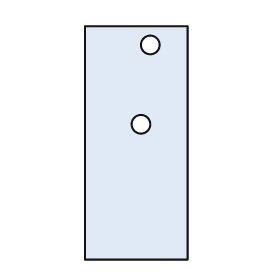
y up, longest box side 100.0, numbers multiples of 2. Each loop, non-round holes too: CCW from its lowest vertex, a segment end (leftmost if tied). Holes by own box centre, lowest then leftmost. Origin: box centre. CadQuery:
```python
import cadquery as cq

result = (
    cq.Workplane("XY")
    .moveTo(-22.0, -50.0)
    .lineTo(22.0, -50.0)
    .lineTo(22.0, 50.0)
    .lineTo(-22.0, 50.0)
    .close()
    .moveTo(2.0, 8.0)
    .circle(4.0)
    .moveTo(6.0, 42.0)
    .circle(4.0)
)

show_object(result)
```